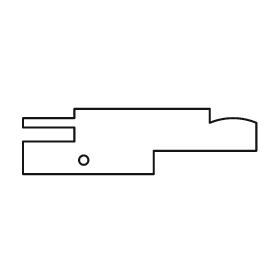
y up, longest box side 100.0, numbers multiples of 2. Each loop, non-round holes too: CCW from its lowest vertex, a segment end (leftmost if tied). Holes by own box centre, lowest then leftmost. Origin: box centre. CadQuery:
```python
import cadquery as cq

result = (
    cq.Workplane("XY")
    .moveTo(-50.0, -14.0)
    .lineTo(6.0, -14.0)
    .lineTo(6.0, -4.0)
    .lineTo(50.0, -4.0)
    .lineTo(50.0, 8.0)
    .threePointArc((40.0, 10.0), (30.0, 8.0))
    .lineTo(30.0, 14.0)
    .lineTo(-28.0, 14.0)
    .lineTo(-28.0, 10.0)
    .lineTo(-50.0, 10.0)
    .lineTo(-50.0, 6.0)
    .lineTo(-28.0, 6.0)
    .lineTo(-28.0, 0.0)
    .lineTo(-50.0, 0.0)
    .close()
    .moveTo(-24.0, -8.0)
    .circle(2.0)
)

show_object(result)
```